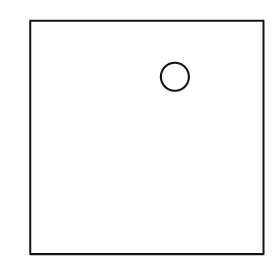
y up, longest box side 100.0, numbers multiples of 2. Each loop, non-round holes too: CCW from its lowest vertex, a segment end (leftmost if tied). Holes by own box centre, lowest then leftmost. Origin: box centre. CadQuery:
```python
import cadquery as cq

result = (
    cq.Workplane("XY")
    .moveTo(-50.0, -50.0)
    .lineTo(50.0, -50.0)
    .lineTo(50.0, 50.0)
    .lineTo(-50.0, 50.0)
    .close()
    .moveTo(12.0, 26.0)
    .circle(6.0)
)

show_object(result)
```